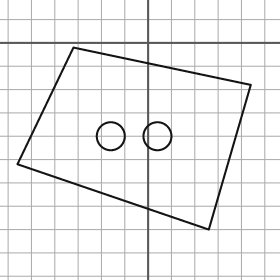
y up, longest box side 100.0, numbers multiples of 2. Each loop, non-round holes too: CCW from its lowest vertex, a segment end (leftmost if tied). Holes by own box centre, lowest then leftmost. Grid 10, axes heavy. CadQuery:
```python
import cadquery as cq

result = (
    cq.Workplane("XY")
    .moveTo(26.0, -80.0)
    .lineTo(44.0, -18.0)
    .lineTo(-32.0, -2.0)
    .lineTo(-56.0, -52.0)
    .close()
    .moveTo(-16.0, -40.0)
    .circle(6.0)
    .moveTo(4.0, -40.0)
    .circle(6.0)
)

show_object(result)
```